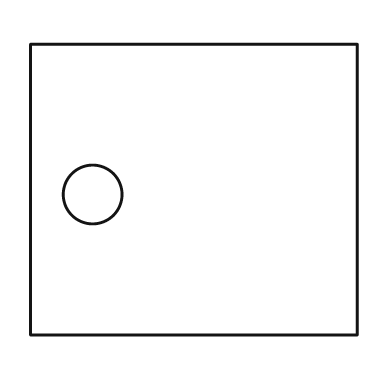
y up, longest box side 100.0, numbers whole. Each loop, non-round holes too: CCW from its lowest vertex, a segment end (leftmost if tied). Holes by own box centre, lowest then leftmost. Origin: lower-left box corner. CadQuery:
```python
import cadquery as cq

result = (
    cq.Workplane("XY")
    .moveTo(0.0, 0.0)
    .lineTo(100.0, 0.0)
    .lineTo(100.0, 89.0)
    .lineTo(0.0, 89.0)
    .close()
    .moveTo(19.0, 43.0)
    .circle(9.0)
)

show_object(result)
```